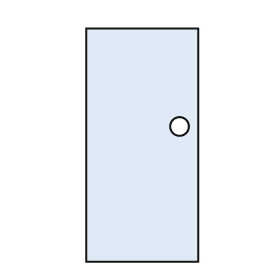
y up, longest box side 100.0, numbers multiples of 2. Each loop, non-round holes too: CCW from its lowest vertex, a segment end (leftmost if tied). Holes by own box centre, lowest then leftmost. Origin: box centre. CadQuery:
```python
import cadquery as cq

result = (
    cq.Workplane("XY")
    .moveTo(-24.0, -50.0)
    .lineTo(24.0, -50.0)
    .lineTo(24.0, 50.0)
    .lineTo(-24.0, 50.0)
    .close()
    .moveTo(16.0, 8.0)
    .circle(4.0)
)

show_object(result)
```